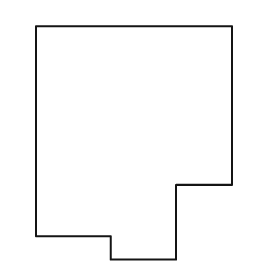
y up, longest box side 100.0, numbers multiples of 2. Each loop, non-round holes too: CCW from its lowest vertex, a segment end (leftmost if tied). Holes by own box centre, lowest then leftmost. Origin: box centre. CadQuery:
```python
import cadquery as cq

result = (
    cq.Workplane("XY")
    .moveTo(-10.0, -50.0)
    .lineTo(18.0, -50.0)
    .lineTo(18.0, -18.0)
    .lineTo(42.0, -18.0)
    .lineTo(42.0, 50.0)
    .lineTo(-42.0, 50.0)
    .lineTo(-42.0, -40.0)
    .lineTo(-10.0, -40.0)
    .close()
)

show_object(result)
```